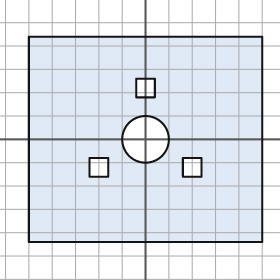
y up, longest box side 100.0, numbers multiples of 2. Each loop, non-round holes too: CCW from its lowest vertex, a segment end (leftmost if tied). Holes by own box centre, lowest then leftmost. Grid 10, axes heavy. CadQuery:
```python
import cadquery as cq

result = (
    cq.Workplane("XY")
    .moveTo(-50.0, -44.0)
    .lineTo(50.0, -44.0)
    .lineTo(50.0, 44.0)
    .lineTo(-50.0, 44.0)
    .close()
    .moveTo(-24.0, -16.0)
    .lineTo(-16.0, -16.0)
    .lineTo(-16.0, -8.0)
    .lineTo(-24.0, -8.0)
    .close()
    .moveTo(16.0, -16.0)
    .lineTo(24.0, -16.0)
    .lineTo(24.0, -8.0)
    .lineTo(16.0, -8.0)
    .close()
    .moveTo(0.0, 0.0)
    .circle(10.0)
    .moveTo(-4.0, 18.0)
    .lineTo(4.0, 18.0)
    .lineTo(4.0, 26.0)
    .lineTo(-4.0, 26.0)
    .close()
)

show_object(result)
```